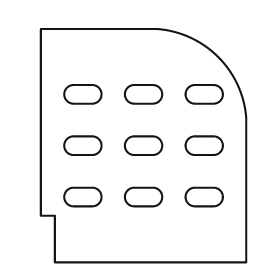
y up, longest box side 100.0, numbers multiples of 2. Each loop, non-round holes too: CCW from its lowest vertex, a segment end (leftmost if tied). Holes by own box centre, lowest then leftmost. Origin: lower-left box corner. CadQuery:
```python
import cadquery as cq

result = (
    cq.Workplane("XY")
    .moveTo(6.0, 0.0)
    .lineTo(88.0, 0.0)
    .lineTo(88.0, 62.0)
    .threePointArc((76.0, 88.0), (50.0, 100.0))
    .lineTo(0.0, 100.0)
    .lineTo(0.0, 20.0)
    .lineTo(6.0, 20.0)
    .close()
    .moveTo(14.0, 24.0)
    .lineTo(22.0, 24.0)
    .threePointArc((26.0, 28.0), (22.0, 32.0))
    .lineTo(14.0, 32.0)
    .threePointArc((10.0, 28.0), (14.0, 24.0))
    .close()
    .moveTo(40.0, 24.0)
    .lineTo(48.0, 24.0)
    .threePointArc((52.0, 28.0), (48.0, 32.0))
    .lineTo(40.0, 32.0)
    .threePointArc((36.0, 28.0), (40.0, 24.0))
    .close()
    .moveTo(66.0, 24.0)
    .lineTo(74.0, 24.0)
    .threePointArc((78.0, 28.0), (74.0, 32.0))
    .lineTo(66.0, 32.0)
    .threePointArc((62.0, 28.0), (66.0, 24.0))
    .close()
    .moveTo(14.0, 46.0)
    .lineTo(22.0, 46.0)
    .threePointArc((26.0, 50.0), (22.0, 54.0))
    .lineTo(14.0, 54.0)
    .threePointArc((10.0, 50.0), (14.0, 46.0))
    .close()
    .moveTo(40.0, 46.0)
    .lineTo(48.0, 46.0)
    .threePointArc((52.0, 50.0), (48.0, 54.0))
    .lineTo(40.0, 54.0)
    .threePointArc((36.0, 50.0), (40.0, 46.0))
    .close()
    .moveTo(66.0, 46.0)
    .lineTo(74.0, 46.0)
    .threePointArc((78.0, 50.0), (74.0, 54.0))
    .lineTo(66.0, 54.0)
    .threePointArc((62.0, 50.0), (66.0, 46.0))
    .close()
    .moveTo(14.0, 68.0)
    .lineTo(22.0, 68.0)
    .threePointArc((26.0, 72.0), (22.0, 76.0))
    .lineTo(14.0, 76.0)
    .threePointArc((10.0, 72.0), (14.0, 68.0))
    .close()
    .moveTo(40.0, 68.0)
    .lineTo(48.0, 68.0)
    .threePointArc((52.0, 72.0), (48.0, 76.0))
    .lineTo(40.0, 76.0)
    .threePointArc((36.0, 72.0), (40.0, 68.0))
    .close()
    .moveTo(66.0, 68.0)
    .lineTo(74.0, 68.0)
    .threePointArc((78.0, 72.0), (74.0, 76.0))
    .lineTo(66.0, 76.0)
    .threePointArc((62.0, 72.0), (66.0, 68.0))
    .close()
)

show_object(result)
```